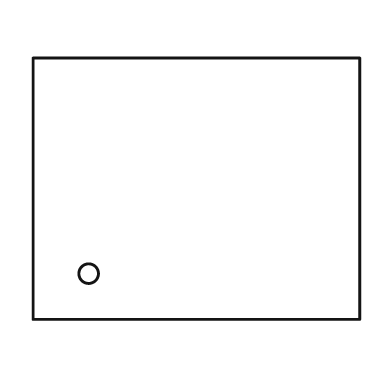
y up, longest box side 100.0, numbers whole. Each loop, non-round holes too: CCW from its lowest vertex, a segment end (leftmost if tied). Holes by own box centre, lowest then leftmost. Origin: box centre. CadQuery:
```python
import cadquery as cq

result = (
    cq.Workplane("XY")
    .moveTo(-50.0, -40.0)
    .lineTo(50.0, -40.0)
    .lineTo(50.0, 40.0)
    .lineTo(-50.0, 40.0)
    .close()
    .moveTo(-33.0, -26.0)
    .circle(3.0)
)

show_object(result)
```